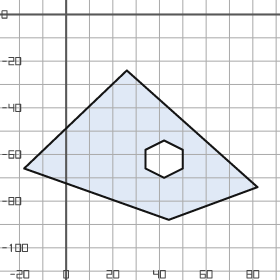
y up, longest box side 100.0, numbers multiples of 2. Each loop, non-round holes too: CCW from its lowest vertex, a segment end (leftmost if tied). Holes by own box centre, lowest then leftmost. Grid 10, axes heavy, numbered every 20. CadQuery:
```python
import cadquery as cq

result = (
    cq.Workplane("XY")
    .moveTo(44.0, -88.0)
    .lineTo(82.0, -74.0)
    .lineTo(26.0, -24.0)
    .lineTo(-18.0, -66.0)
    .close()
    .moveTo(42.0, -70.0)
    .lineTo(50.0, -66.0)
    .lineTo(50.0, -58.0)
    .lineTo(42.0, -54.0)
    .lineTo(34.0, -58.0)
    .lineTo(34.0, -66.0)
    .close()
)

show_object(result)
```